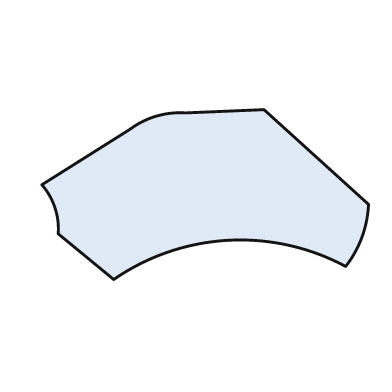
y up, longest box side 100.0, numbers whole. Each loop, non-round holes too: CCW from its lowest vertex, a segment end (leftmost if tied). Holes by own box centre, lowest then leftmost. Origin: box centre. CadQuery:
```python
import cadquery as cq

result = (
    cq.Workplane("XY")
    .moveTo(-28.0, -26.0)
    .threePointArc((7.0, -14.0), (43.0, -22.0))
    .threePointArc((48.0, -13.0), (50.0, -3.0))
    .lineTo(18.0, 26.0)
    .lineTo(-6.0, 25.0)
    .threePointArc((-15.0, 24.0), (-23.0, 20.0))
    .lineTo(-50.0, 3.0)
    .threePointArc((-46.0, -4.0), (-45.0, -12.0))
    .close()
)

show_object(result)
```